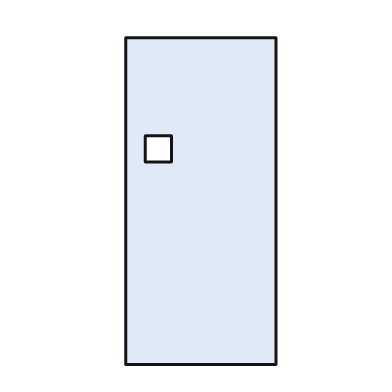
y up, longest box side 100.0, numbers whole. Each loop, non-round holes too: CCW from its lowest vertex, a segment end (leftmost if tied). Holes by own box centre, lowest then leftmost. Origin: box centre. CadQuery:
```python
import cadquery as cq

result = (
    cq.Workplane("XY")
    .moveTo(-23.0, -50.0)
    .lineTo(23.0, -50.0)
    .lineTo(23.0, 50.0)
    .lineTo(-23.0, 50.0)
    .close()
    .moveTo(-17.0, 12.0)
    .lineTo(-9.0, 12.0)
    .lineTo(-9.0, 20.0)
    .lineTo(-17.0, 20.0)
    .close()
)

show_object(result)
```